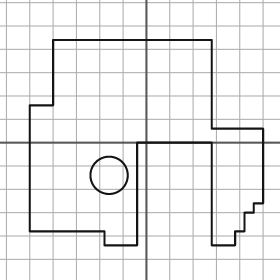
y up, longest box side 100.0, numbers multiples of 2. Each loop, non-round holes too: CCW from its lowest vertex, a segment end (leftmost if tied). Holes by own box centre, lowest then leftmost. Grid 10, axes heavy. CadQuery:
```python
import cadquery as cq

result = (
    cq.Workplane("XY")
    .moveTo(-18.0, -44.0)
    .lineTo(-4.0, -44.0)
    .lineTo(-4.0, 0.0)
    .lineTo(28.0, 0.0)
    .lineTo(28.0, -44.0)
    .lineTo(38.0, -44.0)
    .lineTo(38.0, -38.0)
    .lineTo(42.0, -38.0)
    .lineTo(42.0, -30.0)
    .lineTo(46.0, -30.0)
    .lineTo(46.0, -26.0)
    .lineTo(50.0, -26.0)
    .lineTo(50.0, 6.0)
    .lineTo(28.0, 6.0)
    .lineTo(28.0, 44.0)
    .lineTo(-40.0, 44.0)
    .lineTo(-40.0, 16.0)
    .lineTo(-50.0, 16.0)
    .lineTo(-50.0, -38.0)
    .lineTo(-18.0, -38.0)
    .close()
    .moveTo(-16.0, -14.0)
    .circle(8.0)
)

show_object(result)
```